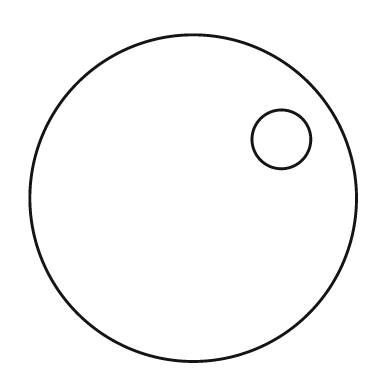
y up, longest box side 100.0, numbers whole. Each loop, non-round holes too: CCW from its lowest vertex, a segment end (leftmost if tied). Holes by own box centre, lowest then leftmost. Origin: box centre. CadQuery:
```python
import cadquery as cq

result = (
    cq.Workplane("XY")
    .moveTo(0.0, 0.0)
    .circle(50.0)
    .moveTo(27.0, 18.0)
    .circle(9.0)
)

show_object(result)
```